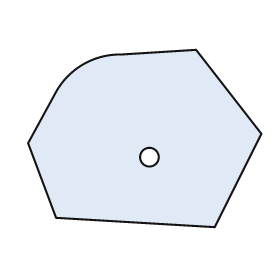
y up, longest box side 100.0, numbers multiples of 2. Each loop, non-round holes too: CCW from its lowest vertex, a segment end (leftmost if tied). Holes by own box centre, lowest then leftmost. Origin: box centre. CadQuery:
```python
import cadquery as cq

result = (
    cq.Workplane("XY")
    .moveTo(30.0, -38.0)
    .lineTo(50.0, 2.0)
    .lineTo(22.0, 38.0)
    .lineTo(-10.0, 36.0)
    .threePointArc((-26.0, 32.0), (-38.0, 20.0))
    .lineTo(-50.0, -2.0)
    .lineTo(-38.0, -34.0)
    .close()
    .moveTo(2.0, -8.0)
    .circle(4.0)
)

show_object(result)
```